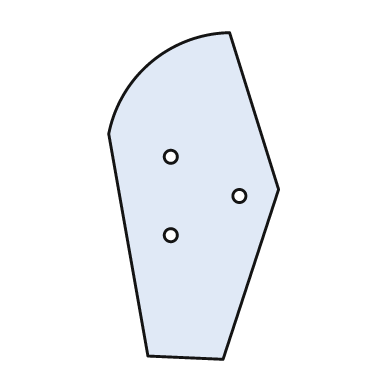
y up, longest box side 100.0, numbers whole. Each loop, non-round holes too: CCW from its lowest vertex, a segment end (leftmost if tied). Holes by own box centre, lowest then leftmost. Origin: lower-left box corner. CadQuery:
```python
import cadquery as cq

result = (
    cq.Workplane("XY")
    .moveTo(35.0, 0.0)
    .lineTo(52.0, 52.0)
    .lineTo(37.0, 100.0)
    .threePointArc((13.0, 91.0), (0.0, 69.0))
    .lineTo(12.0, 1.0)
    .close()
    .moveTo(19.0, 38.0)
    .circle(2.0)
    .moveTo(40.0, 50.0)
    .circle(2.0)
    .moveTo(19.0, 62.0)
    .circle(2.0)
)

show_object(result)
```